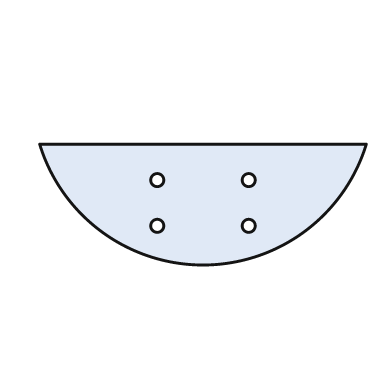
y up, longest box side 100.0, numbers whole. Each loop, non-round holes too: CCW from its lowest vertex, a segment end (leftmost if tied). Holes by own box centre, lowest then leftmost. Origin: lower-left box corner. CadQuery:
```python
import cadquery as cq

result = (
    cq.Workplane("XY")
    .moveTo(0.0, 37.0)
    .threePointArc((50.0, 0.0), (100.0, 37.0))
    .close()
    .moveTo(36.0, 12.0)
    .circle(2.0)
    .moveTo(64.0, 12.0)
    .circle(2.0)
    .moveTo(36.0, 26.0)
    .circle(2.0)
    .moveTo(64.0, 26.0)
    .circle(2.0)
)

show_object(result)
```